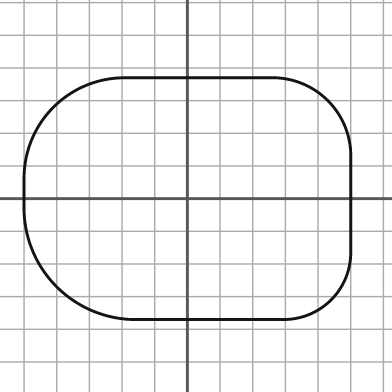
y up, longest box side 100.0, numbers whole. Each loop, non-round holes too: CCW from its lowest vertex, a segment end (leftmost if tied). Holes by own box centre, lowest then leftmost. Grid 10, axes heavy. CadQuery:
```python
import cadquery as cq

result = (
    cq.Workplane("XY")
    .moveTo(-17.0, -37.0)
    .lineTo(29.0, -37.0)
    .threePointArc((44.0, -31.0), (50.0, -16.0))
    .lineTo(50.0, 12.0)
    .threePointArc((43.0, 30.0), (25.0, 37.0))
    .lineTo(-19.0, 37.0)
    .threePointArc((-41.0, 28.0), (-50.0, 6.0))
    .lineTo(-50.0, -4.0)
    .threePointArc((-40.0, -27.0), (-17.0, -37.0))
    .close()
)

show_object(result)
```